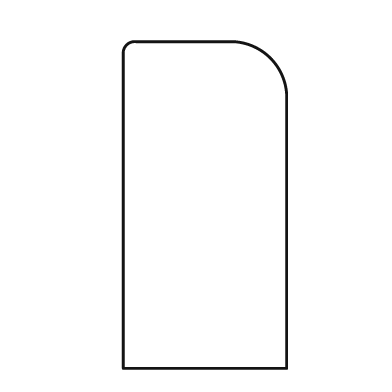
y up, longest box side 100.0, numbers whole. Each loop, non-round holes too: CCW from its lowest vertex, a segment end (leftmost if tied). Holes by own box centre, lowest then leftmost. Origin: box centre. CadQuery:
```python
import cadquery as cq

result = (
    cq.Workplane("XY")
    .moveTo(-25.0, -50.0)
    .lineTo(25.0, -50.0)
    .lineTo(25.0, 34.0)
    .threePointArc((20.0, 45.0), (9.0, 50.0))
    .lineTo(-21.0, 50.0)
    .threePointArc((-24.0, 49.0), (-25.0, 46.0))
    .close()
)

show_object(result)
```